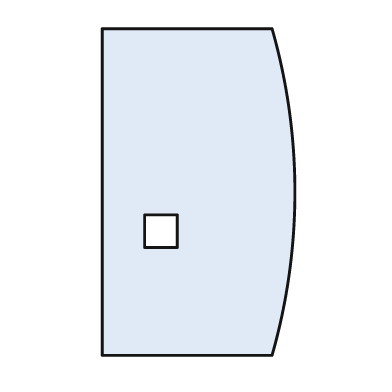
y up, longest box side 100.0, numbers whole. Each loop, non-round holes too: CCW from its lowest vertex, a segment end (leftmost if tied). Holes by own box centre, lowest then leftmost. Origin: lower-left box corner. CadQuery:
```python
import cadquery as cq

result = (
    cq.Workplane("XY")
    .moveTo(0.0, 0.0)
    .lineTo(52.0, 0.0)
    .threePointArc((59.0, 50.0), (52.0, 100.0))
    .lineTo(0.0, 100.0)
    .close()
    .moveTo(13.0, 33.0)
    .lineTo(23.0, 33.0)
    .lineTo(23.0, 43.0)
    .lineTo(13.0, 43.0)
    .close()
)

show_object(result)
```